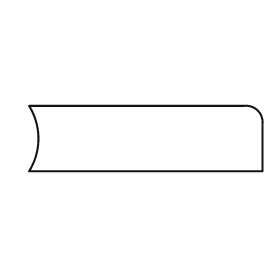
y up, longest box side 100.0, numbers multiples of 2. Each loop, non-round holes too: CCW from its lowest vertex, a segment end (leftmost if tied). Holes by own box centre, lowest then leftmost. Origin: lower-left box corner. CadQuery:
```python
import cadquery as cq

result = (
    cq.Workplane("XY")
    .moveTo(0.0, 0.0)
    .lineTo(100.0, 0.0)
    .lineTo(100.0, 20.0)
    .threePointArc((98.0, 26.0), (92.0, 28.0))
    .lineTo(0.0, 28.0)
    .threePointArc((4.0, 14.0), (0.0, 0.0))
    .close()
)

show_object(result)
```